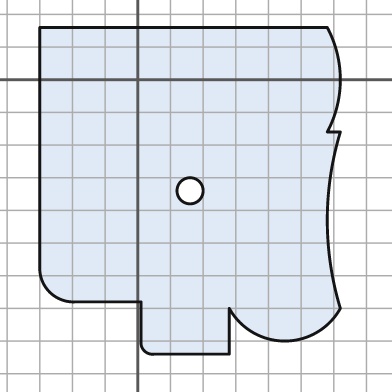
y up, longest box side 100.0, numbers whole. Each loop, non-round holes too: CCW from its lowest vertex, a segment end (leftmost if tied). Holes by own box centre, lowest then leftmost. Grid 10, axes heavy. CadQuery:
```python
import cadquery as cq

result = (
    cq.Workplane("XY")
    .moveTo(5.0, -84.0)
    .lineTo(28.0, -84.0)
    .lineTo(28.0, -70.0)
    .threePointArc((45.0, -80.0), (62.0, -70.0))
    .threePointArc((58.0, -43.0), (62.0, -16.0))
    .lineTo(58.0, -16.0)
    .threePointArc((62.0, 0.0), (58.0, 16.0))
    .lineTo(-30.0, 16.0)
    .lineTo(-30.0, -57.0)
    .threePointArc((-27.0, -65.0), (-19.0, -68.0))
    .lineTo(1.0, -68.0)
    .lineTo(1.0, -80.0)
    .threePointArc((2.0, -83.0), (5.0, -84.0))
    .close()
    .moveTo(16.0, -34.0)
    .circle(4.0)
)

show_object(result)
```